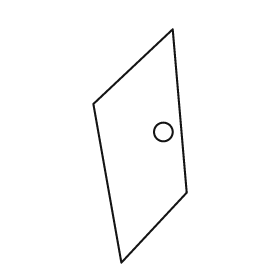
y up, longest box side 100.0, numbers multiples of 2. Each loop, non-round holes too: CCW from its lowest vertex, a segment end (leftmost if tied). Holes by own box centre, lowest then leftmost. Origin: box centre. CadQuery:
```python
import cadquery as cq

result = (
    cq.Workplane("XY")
    .moveTo(-8.0, -50.0)
    .lineTo(20.0, -20.0)
    .lineTo(14.0, 50.0)
    .lineTo(-20.0, 18.0)
    .close()
    .moveTo(10.0, 6.0)
    .circle(4.0)
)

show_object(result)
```